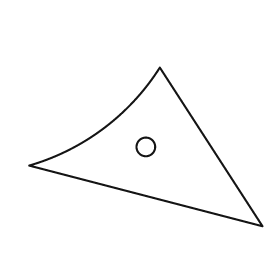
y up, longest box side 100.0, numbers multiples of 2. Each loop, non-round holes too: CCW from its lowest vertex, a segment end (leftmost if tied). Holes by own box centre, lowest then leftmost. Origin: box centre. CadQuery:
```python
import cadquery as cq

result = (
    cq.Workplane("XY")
    .moveTo(50.0, -34.0)
    .lineTo(6.0, 34.0)
    .threePointArc((-18.0, 8.0), (-50.0, -8.0))
    .close()
    .moveTo(0.0, 0.0)
    .circle(4.0)
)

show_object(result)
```